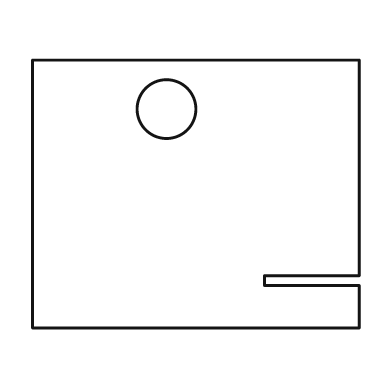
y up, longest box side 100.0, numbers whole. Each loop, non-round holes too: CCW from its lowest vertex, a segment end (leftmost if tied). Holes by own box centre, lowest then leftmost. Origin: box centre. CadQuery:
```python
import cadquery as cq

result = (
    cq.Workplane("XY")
    .moveTo(-50.0, -41.0)
    .lineTo(50.0, -41.0)
    .lineTo(50.0, -28.0)
    .lineTo(21.0, -28.0)
    .lineTo(21.0, -25.0)
    .lineTo(50.0, -25.0)
    .lineTo(50.0, 41.0)
    .lineTo(-50.0, 41.0)
    .close()
    .moveTo(-9.0, 26.0)
    .circle(9.0)
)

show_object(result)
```